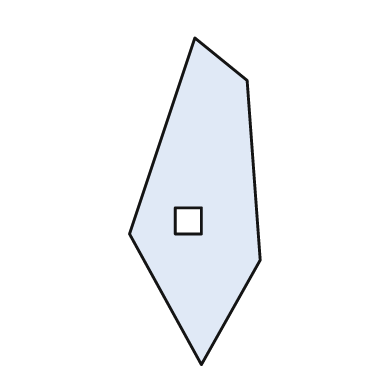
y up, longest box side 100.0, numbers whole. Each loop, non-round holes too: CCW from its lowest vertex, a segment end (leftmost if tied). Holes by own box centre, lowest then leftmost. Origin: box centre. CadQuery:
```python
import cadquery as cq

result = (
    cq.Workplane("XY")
    .moveTo(2.0, -50.0)
    .lineTo(20.0, -18.0)
    .lineTo(16.0, 37.0)
    .lineTo(0.0, 50.0)
    .lineTo(-20.0, -10.0)
    .close()
    .moveTo(-6.0, -10.0)
    .lineTo(2.0, -10.0)
    .lineTo(2.0, -2.0)
    .lineTo(-6.0, -2.0)
    .close()
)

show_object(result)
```